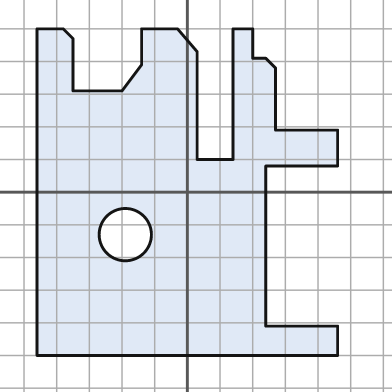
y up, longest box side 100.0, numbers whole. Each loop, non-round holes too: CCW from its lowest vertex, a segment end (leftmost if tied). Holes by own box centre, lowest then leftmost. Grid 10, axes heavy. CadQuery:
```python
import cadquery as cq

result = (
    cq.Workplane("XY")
    .moveTo(-46.0, -50.0)
    .lineTo(46.0, -50.0)
    .lineTo(46.0, -41.0)
    .lineTo(24.0, -41.0)
    .lineTo(24.0, 8.0)
    .lineTo(46.0, 8.0)
    .lineTo(46.0, 19.0)
    .lineTo(27.0, 19.0)
    .lineTo(27.0, 38.0)
    .lineTo(24.0, 41.0)
    .lineTo(20.0, 41.0)
    .lineTo(20.0, 50.0)
    .lineTo(14.0, 50.0)
    .lineTo(14.0, 10.0)
    .lineTo(3.0, 10.0)
    .lineTo(3.0, 43.0)
    .lineTo(-3.0, 50.0)
    .lineTo(-14.0, 50.0)
    .lineTo(-14.0, 39.0)
    .lineTo(-20.0, 31.0)
    .lineTo(-35.0, 31.0)
    .lineTo(-35.0, 47.0)
    .lineTo(-38.0, 50.0)
    .lineTo(-46.0, 50.0)
    .close()
    .moveTo(-19.0, -13.0)
    .circle(8.0)
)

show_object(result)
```